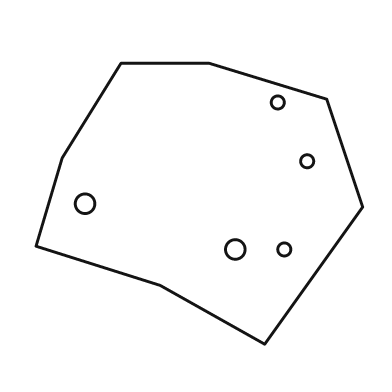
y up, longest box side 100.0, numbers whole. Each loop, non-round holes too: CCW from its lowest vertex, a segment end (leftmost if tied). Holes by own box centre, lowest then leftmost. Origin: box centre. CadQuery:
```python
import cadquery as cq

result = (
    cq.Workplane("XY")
    .moveTo(20.0, -43.0)
    .lineTo(50.0, -1.0)
    .lineTo(39.0, 32.0)
    .lineTo(3.0, 43.0)
    .lineTo(-24.0, 43.0)
    .lineTo(-42.0, 14.0)
    .lineTo(-50.0, -13.0)
    .lineTo(-12.0, -25.0)
    .close()
    .moveTo(11.0, -14.0)
    .circle(3.0)
    .moveTo(26.0, -14.0)
    .circle(2.0)
    .moveTo(-35.0, 0.0)
    .circle(3.0)
    .moveTo(33.0, 13.0)
    .circle(2.0)
    .moveTo(24.0, 31.0)
    .circle(2.0)
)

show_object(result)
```